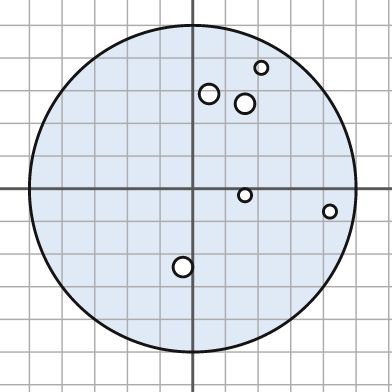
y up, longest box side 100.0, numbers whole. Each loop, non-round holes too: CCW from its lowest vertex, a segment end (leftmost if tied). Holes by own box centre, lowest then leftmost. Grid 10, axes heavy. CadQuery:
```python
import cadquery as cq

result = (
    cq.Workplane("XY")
    .moveTo(0.0, 0.0)
    .circle(50.0)
    .moveTo(-3.0, -24.0)
    .circle(3.0)
    .moveTo(42.0, -7.0)
    .circle(2.0)
    .moveTo(16.0, -2.0)
    .circle(2.0)
    .moveTo(16.0, 26.0)
    .circle(3.0)
    .moveTo(5.0, 29.0)
    .circle(3.0)
    .moveTo(21.0, 37.0)
    .circle(2.0)
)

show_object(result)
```